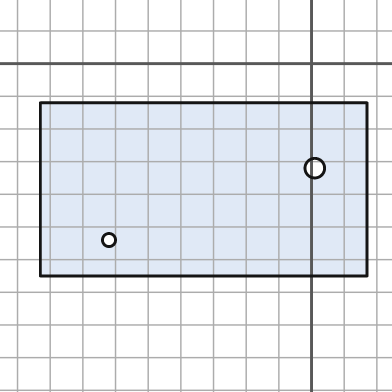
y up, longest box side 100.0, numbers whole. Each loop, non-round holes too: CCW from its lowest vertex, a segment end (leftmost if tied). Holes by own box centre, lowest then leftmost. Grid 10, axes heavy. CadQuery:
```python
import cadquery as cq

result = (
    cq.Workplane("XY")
    .moveTo(-83.0, -65.0)
    .lineTo(17.0, -65.0)
    .lineTo(17.0, -12.0)
    .lineTo(-83.0, -12.0)
    .close()
    .moveTo(-62.0, -54.0)
    .circle(2.0)
    .moveTo(1.0, -32.0)
    .circle(3.0)
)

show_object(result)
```